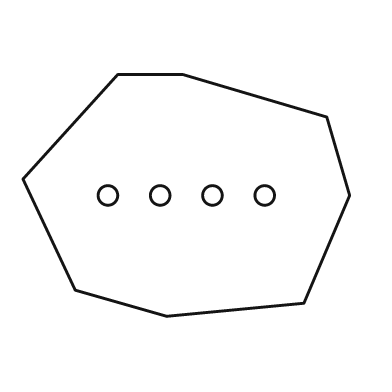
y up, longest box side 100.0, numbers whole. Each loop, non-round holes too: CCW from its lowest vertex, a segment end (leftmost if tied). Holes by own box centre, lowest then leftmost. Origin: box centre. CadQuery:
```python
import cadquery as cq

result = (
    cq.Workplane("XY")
    .moveTo(-6.0, -37.0)
    .lineTo(36.0, -33.0)
    .lineTo(50.0, 0.0)
    .lineTo(43.0, 24.0)
    .lineTo(-1.0, 37.0)
    .lineTo(-21.0, 37.0)
    .lineTo(-50.0, 5.0)
    .lineTo(-34.0, -29.0)
    .close()
    .moveTo(-24.0, 0.0)
    .circle(3.0)
    .moveTo(-8.0, 0.0)
    .circle(3.0)
    .moveTo(8.0, 0.0)
    .circle(3.0)
    .moveTo(24.0, 0.0)
    .circle(3.0)
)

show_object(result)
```